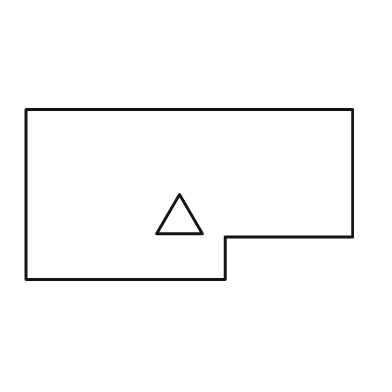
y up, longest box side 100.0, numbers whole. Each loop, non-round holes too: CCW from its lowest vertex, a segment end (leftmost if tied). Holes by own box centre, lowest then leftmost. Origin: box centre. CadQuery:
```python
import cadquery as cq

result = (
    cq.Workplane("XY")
    .moveTo(-50.0, -26.0)
    .lineTo(11.0, -26.0)
    .lineTo(11.0, -13.0)
    .lineTo(50.0, -13.0)
    .lineTo(50.0, 26.0)
    .lineTo(-50.0, 26.0)
    .close()
    .moveTo(-10.0, -12.0)
    .lineTo(4.0, -12.0)
    .lineTo(-3.0, 0.0)
    .close()
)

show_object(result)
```